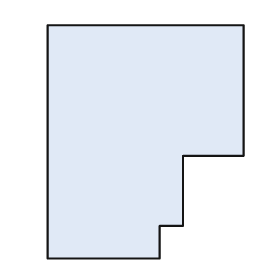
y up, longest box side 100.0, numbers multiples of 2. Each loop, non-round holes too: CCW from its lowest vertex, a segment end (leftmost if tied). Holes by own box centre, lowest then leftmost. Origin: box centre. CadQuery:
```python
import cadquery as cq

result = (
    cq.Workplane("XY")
    .moveTo(-42.0, -50.0)
    .lineTo(6.0, -50.0)
    .lineTo(6.0, -36.0)
    .lineTo(16.0, -36.0)
    .lineTo(16.0, -6.0)
    .lineTo(42.0, -6.0)
    .lineTo(42.0, 50.0)
    .lineTo(-42.0, 50.0)
    .close()
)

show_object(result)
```